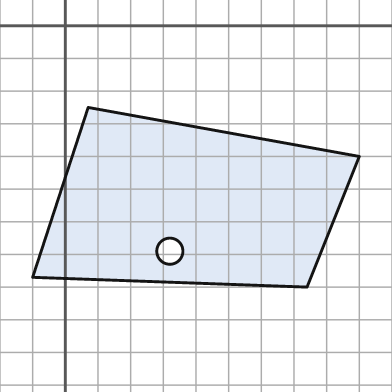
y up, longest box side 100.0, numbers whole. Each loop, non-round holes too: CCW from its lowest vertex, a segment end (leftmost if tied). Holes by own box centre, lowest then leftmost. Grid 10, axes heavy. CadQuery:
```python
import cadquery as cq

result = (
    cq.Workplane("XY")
    .moveTo(74.0, -80.0)
    .lineTo(90.0, -40.0)
    .lineTo(7.0, -25.0)
    .lineTo(-10.0, -77.0)
    .close()
    .moveTo(32.0, -69.0)
    .circle(4.0)
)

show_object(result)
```